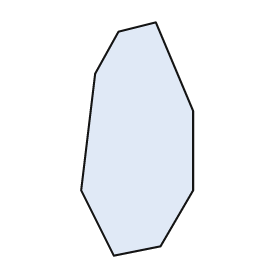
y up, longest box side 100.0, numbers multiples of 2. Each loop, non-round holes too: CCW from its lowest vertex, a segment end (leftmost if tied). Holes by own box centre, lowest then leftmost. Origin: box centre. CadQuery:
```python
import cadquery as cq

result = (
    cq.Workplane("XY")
    .moveTo(-10.0, -50.0)
    .lineTo(10.0, -46.0)
    .lineTo(24.0, -22.0)
    .lineTo(24.0, 12.0)
    .lineTo(8.0, 50.0)
    .lineTo(-8.0, 46.0)
    .lineTo(-18.0, 28.0)
    .lineTo(-24.0, -22.0)
    .close()
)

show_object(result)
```